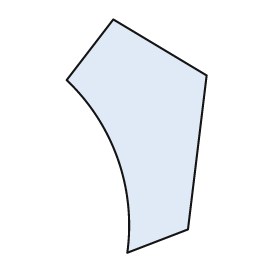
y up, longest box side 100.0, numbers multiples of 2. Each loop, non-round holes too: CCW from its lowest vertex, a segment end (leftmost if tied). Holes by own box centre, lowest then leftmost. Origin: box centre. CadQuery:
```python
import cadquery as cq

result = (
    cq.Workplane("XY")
    .moveTo(-4.0, -50.0)
    .lineTo(22.0, -40.0)
    .lineTo(30.0, 26.0)
    .lineTo(-10.0, 50.0)
    .lineTo(-30.0, 24.0)
    .threePointArc((-8.0, -10.0), (-4.0, -50.0))
    .close()
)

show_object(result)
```